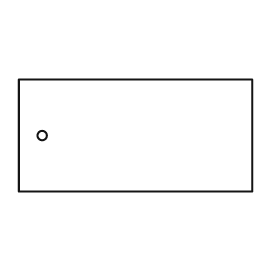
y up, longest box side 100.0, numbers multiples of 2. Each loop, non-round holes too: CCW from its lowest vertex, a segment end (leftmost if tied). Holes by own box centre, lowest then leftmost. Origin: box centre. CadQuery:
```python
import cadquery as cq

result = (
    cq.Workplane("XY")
    .moveTo(-50.0, -24.0)
    .lineTo(50.0, -24.0)
    .lineTo(50.0, 24.0)
    .lineTo(-50.0, 24.0)
    .close()
    .moveTo(-40.0, 0.0)
    .circle(2.0)
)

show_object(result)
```